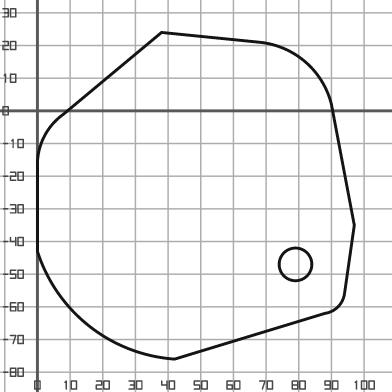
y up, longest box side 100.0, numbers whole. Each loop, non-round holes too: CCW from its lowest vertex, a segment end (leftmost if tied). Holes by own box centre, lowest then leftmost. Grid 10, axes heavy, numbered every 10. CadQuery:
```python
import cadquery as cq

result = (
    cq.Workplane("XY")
    .moveTo(42.0, -76.0)
    .lineTo(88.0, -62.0)
    .threePointArc((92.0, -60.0), (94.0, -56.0))
    .lineTo(97.0, -35.0)
    .lineTo(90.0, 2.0)
    .threePointArc((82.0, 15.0), (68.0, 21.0))
    .lineTo(38.0, 24.0)
    .lineTo(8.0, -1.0)
    .threePointArc((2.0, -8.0), (0.0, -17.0))
    .lineTo(0.0, -43.0)
    .threePointArc((16.0, -66.0), (42.0, -76.0))
    .close()
    .moveTo(79.0, -47.0)
    .circle(5.0)
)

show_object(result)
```